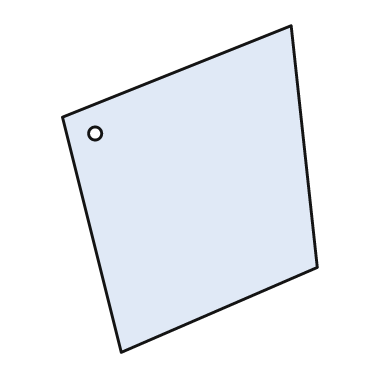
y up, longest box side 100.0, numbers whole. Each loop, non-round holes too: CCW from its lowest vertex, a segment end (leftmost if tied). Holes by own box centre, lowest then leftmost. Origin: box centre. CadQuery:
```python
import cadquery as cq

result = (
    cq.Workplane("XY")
    .moveTo(-21.0, -50.0)
    .lineTo(39.0, -24.0)
    .lineTo(31.0, 50.0)
    .lineTo(-39.0, 22.0)
    .close()
    .moveTo(-29.0, 17.0)
    .circle(2.0)
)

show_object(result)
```